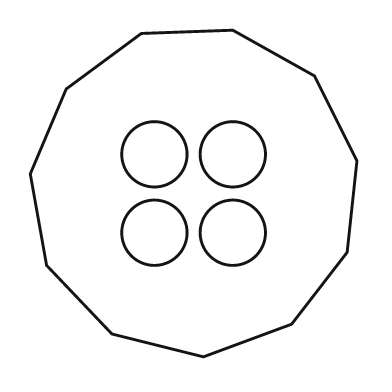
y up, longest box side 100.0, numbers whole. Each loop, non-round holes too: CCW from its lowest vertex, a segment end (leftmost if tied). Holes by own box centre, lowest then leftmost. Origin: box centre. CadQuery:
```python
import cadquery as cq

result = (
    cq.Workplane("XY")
    .moveTo(3.0, -50.0)
    .lineTo(30.0, -40.0)
    .lineTo(47.0, -18.0)
    .lineTo(50.0, 10.0)
    .lineTo(37.0, 36.0)
    .lineTo(12.0, 50.0)
    .lineTo(-16.0, 49.0)
    .lineTo(-39.0, 32.0)
    .lineTo(-50.0, 6.0)
    .lineTo(-45.0, -22.0)
    .lineTo(-25.0, -43.0)
    .close()
    .moveTo(-12.0, -12.0)
    .circle(10.0)
    .moveTo(12.0, -12.0)
    .circle(10.0)
    .moveTo(-12.0, 12.0)
    .circle(10.0)
    .moveTo(12.0, 12.0)
    .circle(10.0)
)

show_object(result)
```